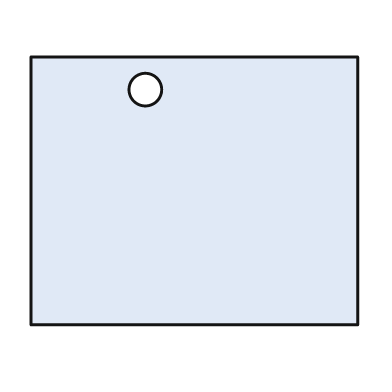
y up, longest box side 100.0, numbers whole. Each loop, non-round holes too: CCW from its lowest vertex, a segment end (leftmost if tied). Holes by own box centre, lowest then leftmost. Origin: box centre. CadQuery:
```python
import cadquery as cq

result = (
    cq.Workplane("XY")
    .moveTo(-50.0, -41.0)
    .lineTo(50.0, -41.0)
    .lineTo(50.0, 41.0)
    .lineTo(-50.0, 41.0)
    .close()
    .moveTo(-15.0, 31.0)
    .circle(5.0)
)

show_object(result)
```